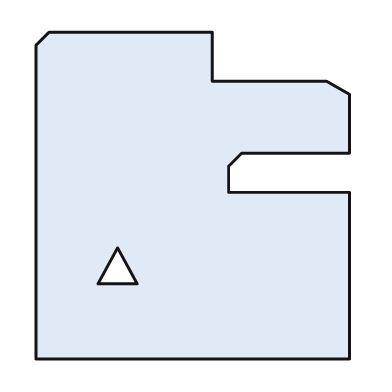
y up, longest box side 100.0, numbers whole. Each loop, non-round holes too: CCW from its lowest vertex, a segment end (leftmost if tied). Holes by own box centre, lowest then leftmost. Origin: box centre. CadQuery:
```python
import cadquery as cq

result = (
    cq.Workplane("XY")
    .moveTo(-48.0, -50.0)
    .lineTo(48.0, -50.0)
    .lineTo(48.0, 1.0)
    .lineTo(11.0, 1.0)
    .lineTo(11.0, 9.0)
    .lineTo(15.0, 13.0)
    .lineTo(48.0, 13.0)
    .lineTo(48.0, 31.0)
    .lineTo(41.0, 35.0)
    .lineTo(6.0, 35.0)
    .lineTo(6.0, 50.0)
    .lineTo(-44.0, 50.0)
    .lineTo(-48.0, 46.0)
    .close()
    .moveTo(-29.0, -27.0)
    .lineTo(-17.0, -27.0)
    .lineTo(-23.0, -16.0)
    .close()
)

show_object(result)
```